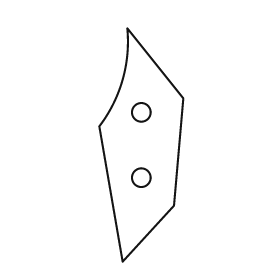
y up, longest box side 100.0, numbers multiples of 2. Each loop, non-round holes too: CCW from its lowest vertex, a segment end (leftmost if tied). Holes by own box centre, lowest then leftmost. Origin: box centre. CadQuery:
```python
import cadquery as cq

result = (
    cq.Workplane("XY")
    .moveTo(-8.0, -50.0)
    .lineTo(14.0, -26.0)
    .lineTo(18.0, 20.0)
    .lineTo(-6.0, 50.0)
    .threePointArc((-8.0, 28.0), (-18.0, 8.0))
    .close()
    .moveTo(0.0, -14.0)
    .circle(4.0)
    .moveTo(0.0, 14.0)
    .circle(4.0)
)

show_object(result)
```